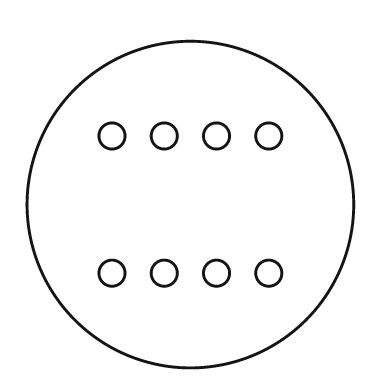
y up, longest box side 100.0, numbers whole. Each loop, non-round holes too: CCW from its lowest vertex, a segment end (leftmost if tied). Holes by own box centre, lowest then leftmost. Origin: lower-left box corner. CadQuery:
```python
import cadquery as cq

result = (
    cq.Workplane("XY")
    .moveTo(50.0, 50.0)
    .circle(50.0)
    .moveTo(26.0, 29.0)
    .circle(4.0)
    .moveTo(42.0, 29.0)
    .circle(4.0)
    .moveTo(58.0, 29.0)
    .circle(4.0)
    .moveTo(74.0, 29.0)
    .circle(4.0)
    .moveTo(26.0, 71.0)
    .circle(4.0)
    .moveTo(42.0, 71.0)
    .circle(4.0)
    .moveTo(58.0, 71.0)
    .circle(4.0)
    .moveTo(74.0, 71.0)
    .circle(4.0)
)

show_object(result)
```